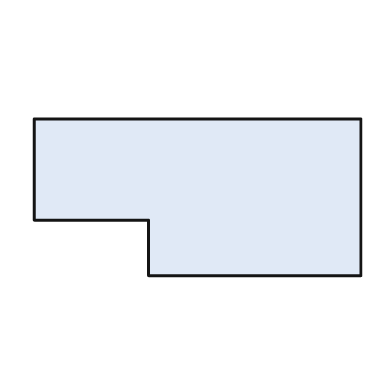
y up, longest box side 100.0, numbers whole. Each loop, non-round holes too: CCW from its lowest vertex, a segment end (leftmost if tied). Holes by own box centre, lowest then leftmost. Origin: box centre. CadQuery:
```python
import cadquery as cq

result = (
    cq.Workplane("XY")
    .moveTo(-15.0, -24.0)
    .lineTo(50.0, -24.0)
    .lineTo(50.0, 24.0)
    .lineTo(-50.0, 24.0)
    .lineTo(-50.0, -7.0)
    .lineTo(-15.0, -7.0)
    .close()
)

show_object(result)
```